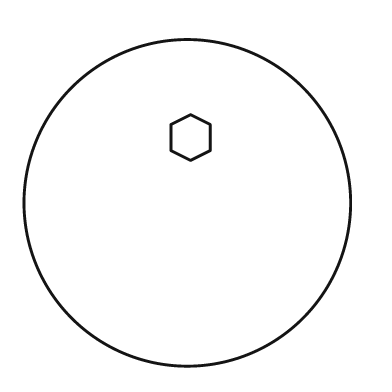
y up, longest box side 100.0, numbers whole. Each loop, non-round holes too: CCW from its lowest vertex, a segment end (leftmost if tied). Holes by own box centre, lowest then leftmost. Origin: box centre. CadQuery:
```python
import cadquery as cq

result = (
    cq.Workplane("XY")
    .moveTo(0.0, 0.0)
    .circle(50.0)
    .moveTo(1.0, 13.0)
    .lineTo(7.0, 16.0)
    .lineTo(7.0, 24.0)
    .lineTo(1.0, 27.0)
    .lineTo(-5.0, 24.0)
    .lineTo(-5.0, 16.0)
    .close()
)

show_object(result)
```